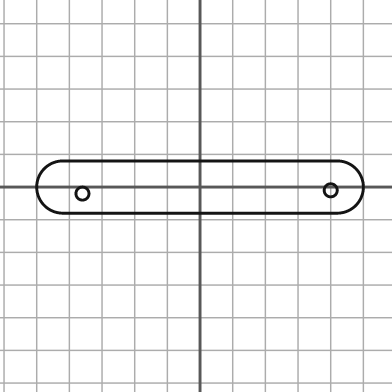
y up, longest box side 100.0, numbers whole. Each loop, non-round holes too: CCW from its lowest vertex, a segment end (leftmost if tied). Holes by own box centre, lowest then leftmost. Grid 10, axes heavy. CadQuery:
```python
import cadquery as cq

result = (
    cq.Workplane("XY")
    .moveTo(-42.0, -8.0)
    .lineTo(42.0, -8.0)
    .threePointArc((50.0, 0.0), (42.0, 8.0))
    .lineTo(-42.0, 8.0)
    .threePointArc((-50.0, 0.0), (-42.0, -8.0))
    .close()
    .moveTo(-36.0, -2.0)
    .circle(2.0)
    .moveTo(40.0, -1.0)
    .circle(2.0)
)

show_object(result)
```